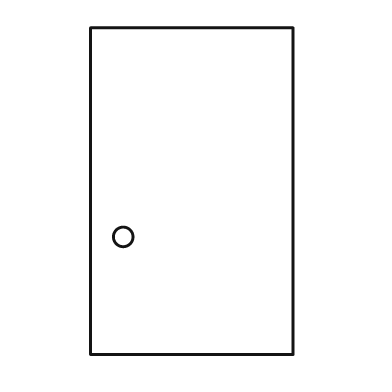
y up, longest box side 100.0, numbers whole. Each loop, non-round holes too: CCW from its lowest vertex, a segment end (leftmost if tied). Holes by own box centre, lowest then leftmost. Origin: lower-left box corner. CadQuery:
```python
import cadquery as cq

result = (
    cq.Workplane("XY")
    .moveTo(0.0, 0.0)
    .lineTo(62.0, 0.0)
    .lineTo(62.0, 100.0)
    .lineTo(0.0, 100.0)
    .close()
    .moveTo(10.0, 36.0)
    .circle(3.0)
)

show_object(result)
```